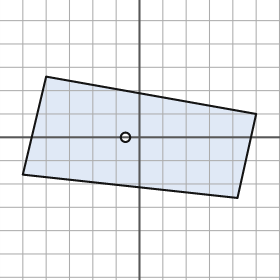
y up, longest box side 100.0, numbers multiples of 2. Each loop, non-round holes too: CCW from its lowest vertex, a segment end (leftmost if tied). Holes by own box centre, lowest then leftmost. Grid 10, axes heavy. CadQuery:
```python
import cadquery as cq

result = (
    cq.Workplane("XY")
    .moveTo(42.0, -26.0)
    .lineTo(50.0, 10.0)
    .lineTo(-40.0, 26.0)
    .lineTo(-50.0, -16.0)
    .close()
    .moveTo(-6.0, 0.0)
    .circle(2.0)
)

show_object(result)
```